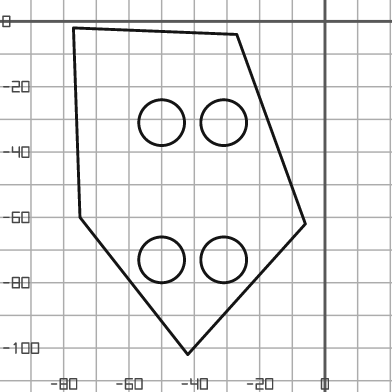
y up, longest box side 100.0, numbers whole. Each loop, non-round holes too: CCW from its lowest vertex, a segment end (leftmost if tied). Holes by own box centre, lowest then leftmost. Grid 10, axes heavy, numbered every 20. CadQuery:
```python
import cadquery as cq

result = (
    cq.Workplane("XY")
    .moveTo(-42.0, -102.0)
    .lineTo(-6.0, -62.0)
    .lineTo(-27.0, -4.0)
    .lineTo(-77.0, -2.0)
    .lineTo(-75.0, -60.0)
    .close()
    .moveTo(-50.0, -73.0)
    .circle(7.0)
    .moveTo(-31.0, -73.0)
    .circle(7.0)
    .moveTo(-50.0, -31.0)
    .circle(7.0)
    .moveTo(-31.0, -31.0)
    .circle(7.0)
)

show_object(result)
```